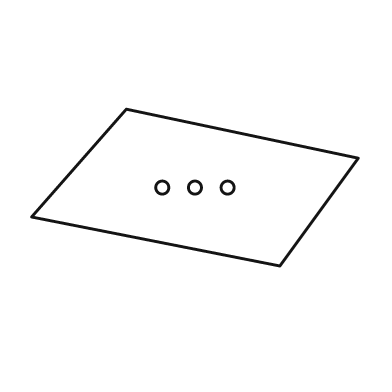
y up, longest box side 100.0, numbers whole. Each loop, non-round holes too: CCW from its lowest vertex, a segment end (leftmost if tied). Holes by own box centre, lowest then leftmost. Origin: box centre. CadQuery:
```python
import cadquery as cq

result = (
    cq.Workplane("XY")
    .moveTo(26.0, -24.0)
    .lineTo(50.0, 9.0)
    .lineTo(-21.0, 24.0)
    .lineTo(-50.0, -9.0)
    .close()
    .moveTo(-10.0, 0.0)
    .circle(2.0)
    .moveTo(0.0, 0.0)
    .circle(2.0)
    .moveTo(10.0, 0.0)
    .circle(2.0)
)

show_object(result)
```